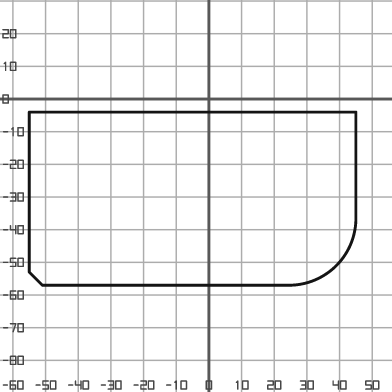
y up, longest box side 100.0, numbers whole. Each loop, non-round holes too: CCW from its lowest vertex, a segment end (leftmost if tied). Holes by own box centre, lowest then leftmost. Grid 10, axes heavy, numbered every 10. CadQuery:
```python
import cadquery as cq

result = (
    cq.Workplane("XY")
    .moveTo(-51.0, -57.0)
    .lineTo(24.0, -57.0)
    .threePointArc((39.0, -51.0), (45.0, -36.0))
    .lineTo(45.0, -4.0)
    .lineTo(-55.0, -4.0)
    .lineTo(-55.0, -53.0)
    .close()
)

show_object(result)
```